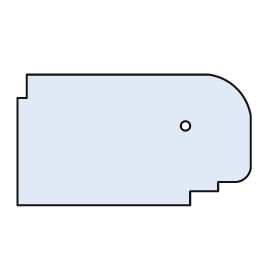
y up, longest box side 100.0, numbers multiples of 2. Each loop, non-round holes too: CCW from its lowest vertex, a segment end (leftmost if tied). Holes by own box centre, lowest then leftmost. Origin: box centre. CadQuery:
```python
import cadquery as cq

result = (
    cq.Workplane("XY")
    .moveTo(-50.0, -28.0)
    .lineTo(24.0, -28.0)
    .lineTo(24.0, -22.0)
    .lineTo(36.0, -22.0)
    .lineTo(36.0, -18.0)
    .lineTo(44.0, -18.0)
    .threePointArc((48.0, -16.0), (50.0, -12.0))
    .lineTo(50.0, 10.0)
    .threePointArc((44.0, 22.0), (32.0, 28.0))
    .lineTo(-46.0, 28.0)
    .lineTo(-46.0, 18.0)
    .lineTo(-50.0, 18.0)
    .close()
    .moveTo(22.0, 6.0)
    .circle(2.0)
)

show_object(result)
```